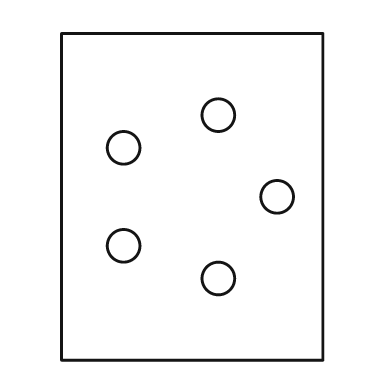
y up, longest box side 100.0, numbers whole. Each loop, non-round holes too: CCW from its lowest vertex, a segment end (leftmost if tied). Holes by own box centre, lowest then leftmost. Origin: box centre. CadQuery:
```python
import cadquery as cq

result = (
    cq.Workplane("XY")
    .moveTo(-40.0, -50.0)
    .lineTo(40.0, -50.0)
    .lineTo(40.0, 50.0)
    .lineTo(-40.0, 50.0)
    .close()
    .moveTo(8.0, -25.0)
    .circle(5.0)
    .moveTo(-21.0, -15.0)
    .circle(5.0)
    .moveTo(26.0, 0.0)
    .circle(5.0)
    .moveTo(-21.0, 15.0)
    .circle(5.0)
    .moveTo(8.0, 25.0)
    .circle(5.0)
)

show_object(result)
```